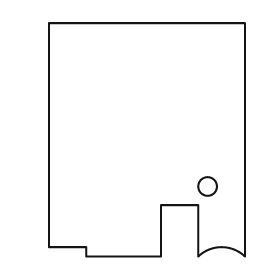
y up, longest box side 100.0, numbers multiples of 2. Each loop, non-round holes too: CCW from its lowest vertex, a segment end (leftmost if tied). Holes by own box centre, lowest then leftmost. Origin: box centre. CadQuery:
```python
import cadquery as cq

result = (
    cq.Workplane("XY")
    .moveTo(-26.0, -50.0)
    .lineTo(6.0, -50.0)
    .lineTo(6.0, -28.0)
    .lineTo(22.0, -28.0)
    .lineTo(22.0, -50.0)
    .threePointArc((32.0, -46.0), (42.0, -50.0))
    .lineTo(42.0, 50.0)
    .lineTo(-42.0, 50.0)
    .lineTo(-42.0, -46.0)
    .lineTo(-26.0, -46.0)
    .close()
    .moveTo(26.0, -20.0)
    .circle(4.0)
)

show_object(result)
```